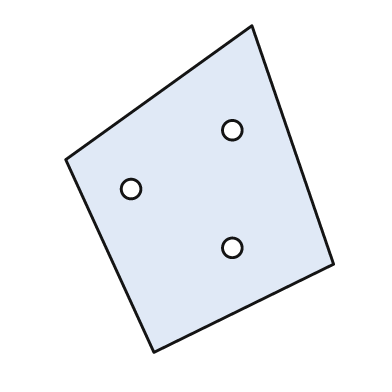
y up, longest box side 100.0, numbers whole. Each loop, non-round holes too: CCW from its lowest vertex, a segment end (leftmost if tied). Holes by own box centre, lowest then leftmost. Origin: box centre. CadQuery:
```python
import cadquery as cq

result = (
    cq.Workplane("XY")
    .moveTo(-14.0, -50.0)
    .lineTo(41.0, -23.0)
    .lineTo(16.0, 50.0)
    .lineTo(-41.0, 9.0)
    .close()
    .moveTo(10.0, -18.0)
    .circle(3.0)
    .moveTo(-21.0, 0.0)
    .circle(3.0)
    .moveTo(10.0, 18.0)
    .circle(3.0)
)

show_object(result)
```